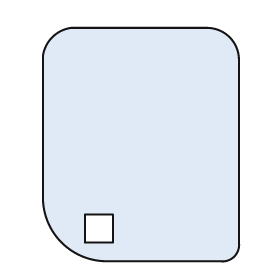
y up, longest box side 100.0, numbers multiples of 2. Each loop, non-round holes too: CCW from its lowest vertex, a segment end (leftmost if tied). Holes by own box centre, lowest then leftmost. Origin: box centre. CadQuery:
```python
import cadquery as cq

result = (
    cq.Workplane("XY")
    .moveTo(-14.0, -50.0)
    .lineTo(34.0, -50.0)
    .threePointArc((40.0, -48.0), (42.0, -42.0))
    .lineTo(42.0, 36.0)
    .threePointArc((38.0, 46.0), (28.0, 50.0))
    .lineTo(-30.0, 50.0)
    .threePointArc((-38.0, 46.0), (-42.0, 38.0))
    .lineTo(-42.0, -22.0)
    .threePointArc((-34.0, -42.0), (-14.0, -50.0))
    .close()
    .moveTo(-24.0, -42.0)
    .lineTo(-12.0, -42.0)
    .lineTo(-12.0, -30.0)
    .lineTo(-24.0, -30.0)
    .close()
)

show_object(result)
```